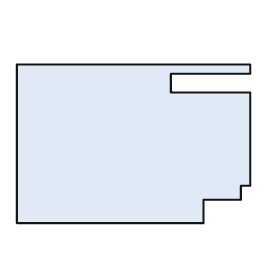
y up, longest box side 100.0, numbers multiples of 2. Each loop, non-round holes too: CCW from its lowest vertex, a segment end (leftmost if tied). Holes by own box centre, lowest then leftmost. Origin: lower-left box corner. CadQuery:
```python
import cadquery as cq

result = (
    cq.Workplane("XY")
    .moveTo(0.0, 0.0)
    .lineTo(80.0, 0.0)
    .lineTo(80.0, 10.0)
    .lineTo(96.0, 10.0)
    .lineTo(96.0, 16.0)
    .lineTo(100.0, 16.0)
    .lineTo(100.0, 56.0)
    .lineTo(66.0, 56.0)
    .lineTo(66.0, 64.0)
    .lineTo(100.0, 64.0)
    .lineTo(100.0, 68.0)
    .lineTo(0.0, 68.0)
    .close()
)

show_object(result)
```